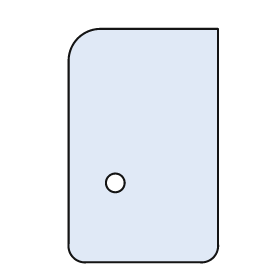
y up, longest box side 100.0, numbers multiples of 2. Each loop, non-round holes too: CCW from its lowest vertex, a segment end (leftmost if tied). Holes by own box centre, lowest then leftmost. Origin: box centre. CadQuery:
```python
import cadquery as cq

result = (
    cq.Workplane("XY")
    .moveTo(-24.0, -50.0)
    .lineTo(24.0, -50.0)
    .threePointArc((30.0, -48.0), (32.0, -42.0))
    .lineTo(32.0, 50.0)
    .lineTo(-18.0, 50.0)
    .threePointArc((-28.0, 46.0), (-32.0, 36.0))
    .lineTo(-32.0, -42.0)
    .threePointArc((-30.0, -48.0), (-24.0, -50.0))
    .close()
    .moveTo(-12.0, -16.0)
    .circle(4.0)
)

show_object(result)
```